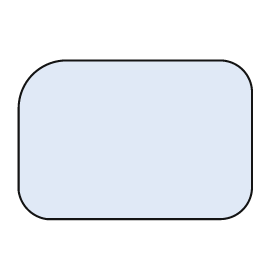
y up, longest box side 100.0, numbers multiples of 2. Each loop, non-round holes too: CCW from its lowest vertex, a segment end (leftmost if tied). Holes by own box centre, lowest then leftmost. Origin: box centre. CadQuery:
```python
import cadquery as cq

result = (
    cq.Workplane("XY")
    .moveTo(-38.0, -34.0)
    .lineTo(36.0, -34.0)
    .threePointArc((46.0, -30.0), (50.0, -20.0))
    .lineTo(50.0, 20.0)
    .threePointArc((46.0, 30.0), (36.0, 34.0))
    .lineTo(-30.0, 34.0)
    .threePointArc((-44.0, 28.0), (-50.0, 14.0))
    .lineTo(-50.0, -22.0)
    .threePointArc((-46.0, -30.0), (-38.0, -34.0))
    .close()
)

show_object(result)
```